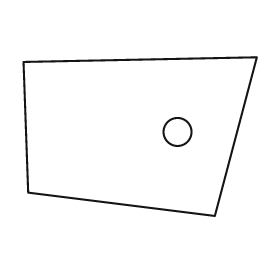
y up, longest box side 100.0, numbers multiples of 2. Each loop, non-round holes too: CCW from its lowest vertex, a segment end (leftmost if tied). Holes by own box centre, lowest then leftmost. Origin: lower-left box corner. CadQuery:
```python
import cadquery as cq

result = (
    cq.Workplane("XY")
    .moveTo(82.0, 0.0)
    .lineTo(100.0, 68.0)
    .lineTo(0.0, 66.0)
    .lineTo(2.0, 10.0)
    .close()
    .moveTo(66.0, 36.0)
    .circle(6.0)
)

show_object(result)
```